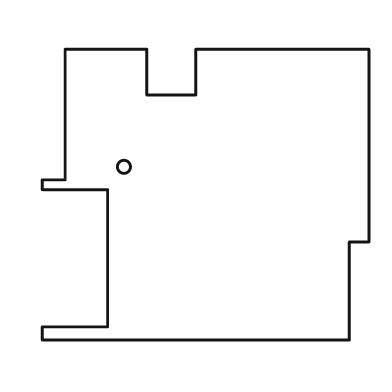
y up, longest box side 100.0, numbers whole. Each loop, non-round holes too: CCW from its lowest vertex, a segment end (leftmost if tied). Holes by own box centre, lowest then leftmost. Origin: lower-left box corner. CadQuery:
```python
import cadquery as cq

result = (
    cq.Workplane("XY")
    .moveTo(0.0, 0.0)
    .lineTo(94.0, 0.0)
    .lineTo(94.0, 30.0)
    .lineTo(100.0, 30.0)
    .lineTo(100.0, 89.0)
    .lineTo(47.0, 89.0)
    .lineTo(47.0, 75.0)
    .lineTo(32.0, 75.0)
    .lineTo(32.0, 89.0)
    .lineTo(7.0, 89.0)
    .lineTo(7.0, 49.0)
    .lineTo(0.0, 49.0)
    .lineTo(0.0, 46.0)
    .lineTo(20.0, 46.0)
    .lineTo(20.0, 4.0)
    .lineTo(0.0, 4.0)
    .close()
    .moveTo(25.0, 53.0)
    .circle(2.0)
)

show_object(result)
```